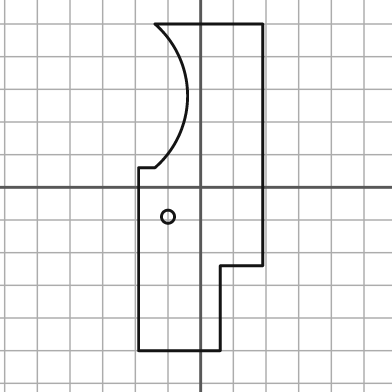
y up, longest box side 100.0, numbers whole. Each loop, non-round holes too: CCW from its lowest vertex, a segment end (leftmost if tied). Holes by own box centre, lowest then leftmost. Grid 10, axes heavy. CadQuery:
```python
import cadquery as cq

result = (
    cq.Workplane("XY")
    .moveTo(-19.0, -50.0)
    .lineTo(6.0, -50.0)
    .lineTo(6.0, -24.0)
    .lineTo(19.0, -24.0)
    .lineTo(19.0, 50.0)
    .lineTo(-14.0, 50.0)
    .threePointArc((-4.0, 28.0), (-14.0, 6.0))
    .lineTo(-19.0, 6.0)
    .close()
    .moveTo(-10.0, -9.0)
    .circle(2.0)
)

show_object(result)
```